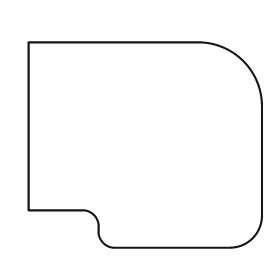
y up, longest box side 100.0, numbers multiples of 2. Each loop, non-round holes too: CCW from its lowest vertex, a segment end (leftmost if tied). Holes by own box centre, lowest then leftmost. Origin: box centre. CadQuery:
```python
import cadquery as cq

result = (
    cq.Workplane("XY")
    .moveTo(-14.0, -44.0)
    .lineTo(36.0, -44.0)
    .threePointArc((46.0, -40.0), (50.0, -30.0))
    .lineTo(50.0, 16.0)
    .threePointArc((42.0, 36.0), (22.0, 44.0))
    .lineTo(-50.0, 44.0)
    .lineTo(-50.0, -28.0)
    .lineTo(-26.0, -28.0)
    .threePointArc((-22.0, -30.0), (-20.0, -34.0))
    .lineTo(-20.0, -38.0)
    .threePointArc((-18.0, -42.0), (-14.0, -44.0))
    .close()
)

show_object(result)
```